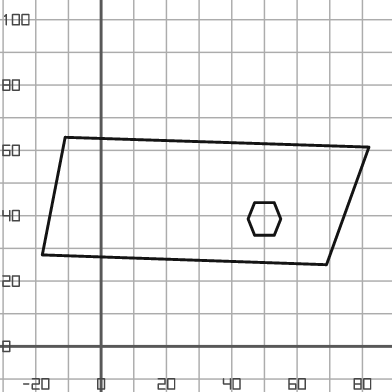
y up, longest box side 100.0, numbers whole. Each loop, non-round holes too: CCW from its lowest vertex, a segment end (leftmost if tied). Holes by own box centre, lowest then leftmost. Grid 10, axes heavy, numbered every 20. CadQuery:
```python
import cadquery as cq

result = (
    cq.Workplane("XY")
    .moveTo(69.0, 25.0)
    .lineTo(82.0, 61.0)
    .lineTo(-11.0, 64.0)
    .lineTo(-18.0, 28.0)
    .close()
    .moveTo(47.0, 34.0)
    .lineTo(53.0, 34.0)
    .lineTo(55.0, 39.0)
    .lineTo(53.0, 44.0)
    .lineTo(47.0, 44.0)
    .lineTo(45.0, 39.0)
    .close()
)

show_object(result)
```